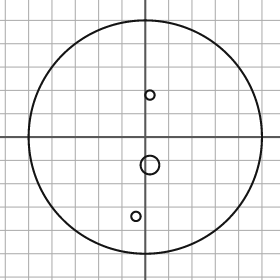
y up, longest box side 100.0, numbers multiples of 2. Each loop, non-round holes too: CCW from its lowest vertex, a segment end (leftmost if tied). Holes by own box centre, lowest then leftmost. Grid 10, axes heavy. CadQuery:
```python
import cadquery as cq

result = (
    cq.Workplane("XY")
    .moveTo(0.0, 0.0)
    .circle(50.0)
    .moveTo(-4.0, -34.0)
    .circle(2.0)
    .moveTo(2.0, -12.0)
    .circle(4.0)
    .moveTo(2.0, 18.0)
    .circle(2.0)
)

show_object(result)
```